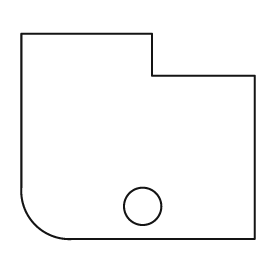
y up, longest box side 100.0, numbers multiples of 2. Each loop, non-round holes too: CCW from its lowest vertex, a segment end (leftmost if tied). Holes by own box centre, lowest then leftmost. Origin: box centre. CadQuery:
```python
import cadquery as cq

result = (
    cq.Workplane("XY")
    .moveTo(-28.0, -44.0)
    .lineTo(50.0, -44.0)
    .lineTo(50.0, 26.0)
    .lineTo(6.0, 26.0)
    .lineTo(6.0, 44.0)
    .lineTo(-50.0, 44.0)
    .lineTo(-50.0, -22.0)
    .threePointArc((-44.0, -38.0), (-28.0, -44.0))
    .close()
    .moveTo(2.0, -30.0)
    .circle(8.0)
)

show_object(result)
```